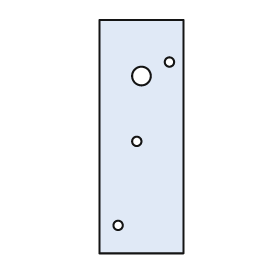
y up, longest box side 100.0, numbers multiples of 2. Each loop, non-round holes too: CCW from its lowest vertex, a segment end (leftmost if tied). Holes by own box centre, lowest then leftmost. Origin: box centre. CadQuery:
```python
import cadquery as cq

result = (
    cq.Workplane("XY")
    .moveTo(-18.0, -50.0)
    .lineTo(18.0, -50.0)
    .lineTo(18.0, 50.0)
    .lineTo(-18.0, 50.0)
    .close()
    .moveTo(-10.0, -38.0)
    .circle(2.0)
    .moveTo(-2.0, -2.0)
    .circle(2.0)
    .moveTo(0.0, 26.0)
    .circle(4.0)
    .moveTo(12.0, 32.0)
    .circle(2.0)
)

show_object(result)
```